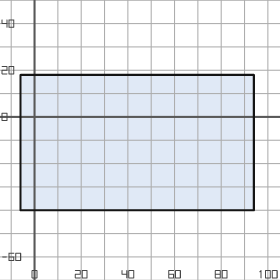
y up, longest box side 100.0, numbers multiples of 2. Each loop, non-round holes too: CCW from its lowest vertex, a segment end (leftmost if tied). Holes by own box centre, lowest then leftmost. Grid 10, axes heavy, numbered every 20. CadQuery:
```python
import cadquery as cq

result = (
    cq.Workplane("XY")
    .moveTo(-6.0, -40.0)
    .lineTo(94.0, -40.0)
    .lineTo(94.0, 18.0)
    .lineTo(-6.0, 18.0)
    .close()
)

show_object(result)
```